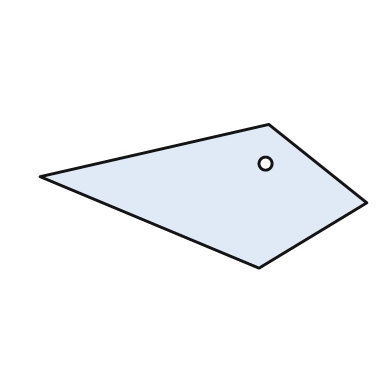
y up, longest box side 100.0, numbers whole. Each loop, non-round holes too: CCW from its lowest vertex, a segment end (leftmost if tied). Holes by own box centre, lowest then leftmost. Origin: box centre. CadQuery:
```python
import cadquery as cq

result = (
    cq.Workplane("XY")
    .moveTo(17.0, -22.0)
    .lineTo(50.0, -2.0)
    .lineTo(20.0, 22.0)
    .lineTo(-50.0, 6.0)
    .close()
    .moveTo(19.0, 10.0)
    .circle(2.0)
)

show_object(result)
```